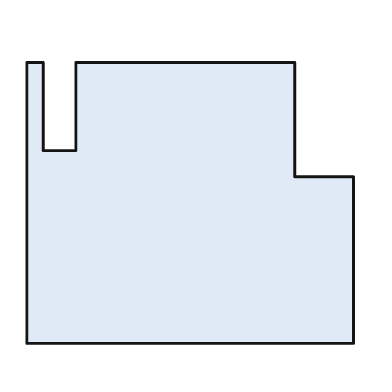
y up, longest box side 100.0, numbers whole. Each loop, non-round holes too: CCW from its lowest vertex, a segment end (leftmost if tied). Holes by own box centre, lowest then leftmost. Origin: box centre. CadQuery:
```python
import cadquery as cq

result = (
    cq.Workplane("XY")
    .moveTo(-50.0, -43.0)
    .lineTo(50.0, -43.0)
    .lineTo(50.0, 8.0)
    .lineTo(32.0, 8.0)
    .lineTo(32.0, 43.0)
    .lineTo(-35.0, 43.0)
    .lineTo(-35.0, 16.0)
    .lineTo(-45.0, 16.0)
    .lineTo(-45.0, 43.0)
    .lineTo(-50.0, 43.0)
    .close()
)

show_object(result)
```